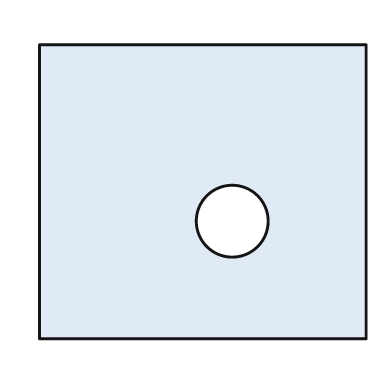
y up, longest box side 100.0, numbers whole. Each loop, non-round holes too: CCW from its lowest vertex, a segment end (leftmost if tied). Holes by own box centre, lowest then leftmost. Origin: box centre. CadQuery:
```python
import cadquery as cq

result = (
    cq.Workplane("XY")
    .moveTo(-50.0, -45.0)
    .lineTo(50.0, -45.0)
    .lineTo(50.0, 45.0)
    .lineTo(-50.0, 45.0)
    .close()
    .moveTo(9.0, -9.0)
    .circle(11.0)
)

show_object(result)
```